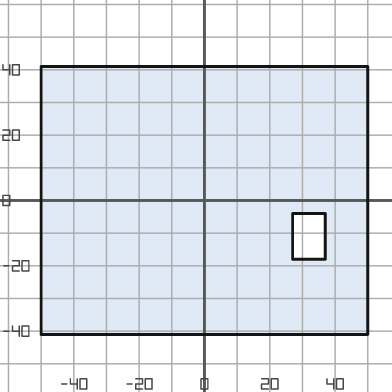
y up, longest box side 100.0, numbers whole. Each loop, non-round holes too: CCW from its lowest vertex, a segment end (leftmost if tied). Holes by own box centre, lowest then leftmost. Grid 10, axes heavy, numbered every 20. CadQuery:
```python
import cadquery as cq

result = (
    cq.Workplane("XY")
    .moveTo(-50.0, -41.0)
    .lineTo(50.0, -41.0)
    .lineTo(50.0, 41.0)
    .lineTo(-50.0, 41.0)
    .close()
    .moveTo(27.0, -18.0)
    .lineTo(37.0, -18.0)
    .lineTo(37.0, -4.0)
    .lineTo(27.0, -4.0)
    .close()
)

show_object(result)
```